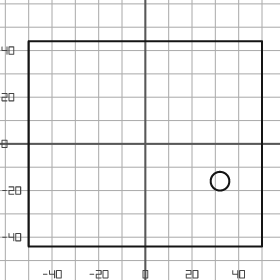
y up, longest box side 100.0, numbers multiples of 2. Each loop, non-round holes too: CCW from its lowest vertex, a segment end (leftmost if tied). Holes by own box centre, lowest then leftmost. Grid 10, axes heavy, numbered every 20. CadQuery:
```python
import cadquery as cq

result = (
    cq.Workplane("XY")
    .moveTo(-50.0, -44.0)
    .lineTo(50.0, -44.0)
    .lineTo(50.0, 44.0)
    .lineTo(-50.0, 44.0)
    .close()
    .moveTo(32.0, -16.0)
    .circle(4.0)
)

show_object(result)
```